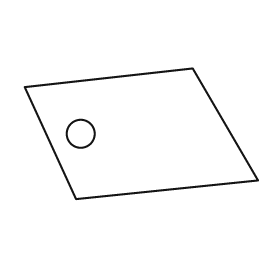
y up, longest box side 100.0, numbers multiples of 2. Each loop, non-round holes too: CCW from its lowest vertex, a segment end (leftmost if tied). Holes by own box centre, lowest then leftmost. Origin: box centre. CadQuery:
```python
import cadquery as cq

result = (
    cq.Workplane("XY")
    .moveTo(-28.0, -28.0)
    .lineTo(50.0, -20.0)
    .lineTo(22.0, 28.0)
    .lineTo(-50.0, 20.0)
    .close()
    .moveTo(-26.0, 0.0)
    .circle(6.0)
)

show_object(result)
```